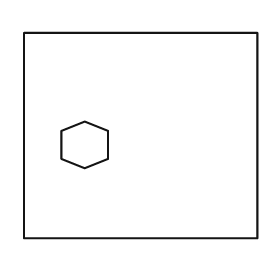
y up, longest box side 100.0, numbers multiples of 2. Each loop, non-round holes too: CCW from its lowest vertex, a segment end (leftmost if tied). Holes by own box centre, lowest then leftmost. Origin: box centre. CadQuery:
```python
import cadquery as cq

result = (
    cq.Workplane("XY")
    .moveTo(-50.0, -44.0)
    .lineTo(50.0, -44.0)
    .lineTo(50.0, 44.0)
    .lineTo(-50.0, 44.0)
    .close()
    .moveTo(-24.0, -14.0)
    .lineTo(-14.0, -10.0)
    .lineTo(-14.0, 2.0)
    .lineTo(-24.0, 6.0)
    .lineTo(-34.0, 2.0)
    .lineTo(-34.0, -10.0)
    .close()
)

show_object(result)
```